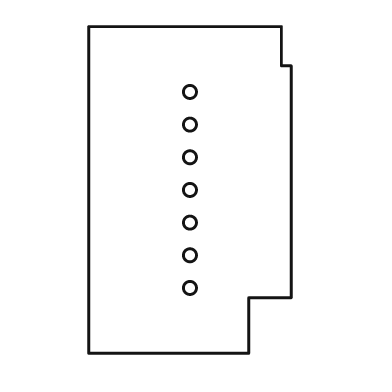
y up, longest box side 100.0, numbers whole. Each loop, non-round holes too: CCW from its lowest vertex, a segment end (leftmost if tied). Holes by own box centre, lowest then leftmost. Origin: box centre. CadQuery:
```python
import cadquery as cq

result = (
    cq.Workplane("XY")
    .moveTo(-31.0, -50.0)
    .lineTo(18.0, -50.0)
    .lineTo(18.0, -33.0)
    .lineTo(31.0, -33.0)
    .lineTo(31.0, 38.0)
    .lineTo(28.0, 38.0)
    .lineTo(28.0, 50.0)
    .lineTo(-31.0, 50.0)
    .close()
    .moveTo(0.0, -30.0)
    .circle(2.0)
    .moveTo(0.0, -20.0)
    .circle(2.0)
    .moveTo(0.0, -10.0)
    .circle(2.0)
    .moveTo(0.0, 0.0)
    .circle(2.0)
    .moveTo(0.0, 10.0)
    .circle(2.0)
    .moveTo(0.0, 20.0)
    .circle(2.0)
    .moveTo(0.0, 30.0)
    .circle(2.0)
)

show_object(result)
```